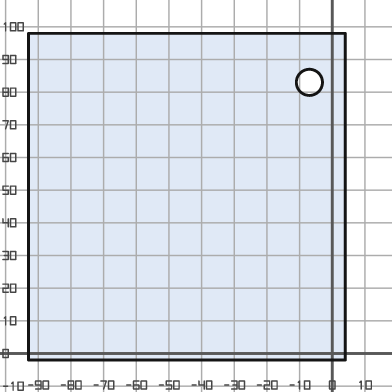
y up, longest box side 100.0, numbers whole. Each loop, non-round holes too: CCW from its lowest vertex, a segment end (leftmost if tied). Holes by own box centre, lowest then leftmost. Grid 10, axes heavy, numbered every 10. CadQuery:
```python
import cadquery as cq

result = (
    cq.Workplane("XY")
    .moveTo(-93.0, -2.0)
    .lineTo(4.0, -2.0)
    .lineTo(4.0, 98.0)
    .lineTo(-93.0, 98.0)
    .close()
    .moveTo(-7.0, 83.0)
    .circle(4.0)
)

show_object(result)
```